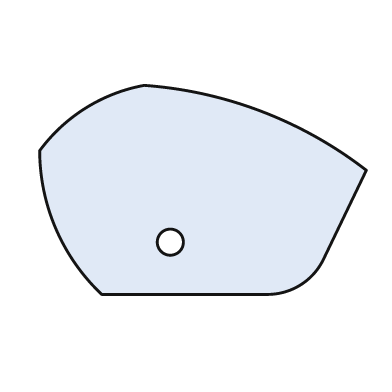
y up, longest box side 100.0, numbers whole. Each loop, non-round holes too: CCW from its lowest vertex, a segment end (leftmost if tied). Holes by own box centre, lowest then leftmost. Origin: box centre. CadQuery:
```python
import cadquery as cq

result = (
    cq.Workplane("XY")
    .moveTo(-31.0, -32.0)
    .lineTo(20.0, -32.0)
    .threePointArc((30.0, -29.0), (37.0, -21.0))
    .lineTo(50.0, 6.0)
    .threePointArc((18.0, 24.0), (-18.0, 32.0))
    .threePointArc((-36.0, 25.0), (-50.0, 12.0))
    .threePointArc((-45.0, -12.0), (-31.0, -32.0))
    .close()
    .moveTo(-10.0, -16.0)
    .circle(4.0)
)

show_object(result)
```